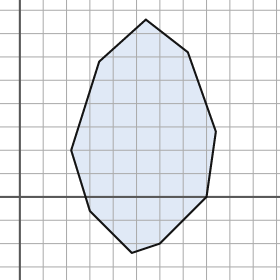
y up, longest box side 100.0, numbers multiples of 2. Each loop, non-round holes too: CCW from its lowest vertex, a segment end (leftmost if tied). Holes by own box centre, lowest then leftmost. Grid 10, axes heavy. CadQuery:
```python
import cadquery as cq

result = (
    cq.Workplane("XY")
    .moveTo(48.0, -24.0)
    .lineTo(60.0, -20.0)
    .lineTo(80.0, 0.0)
    .lineTo(84.0, 28.0)
    .lineTo(72.0, 62.0)
    .lineTo(54.0, 76.0)
    .lineTo(34.0, 58.0)
    .lineTo(22.0, 20.0)
    .lineTo(30.0, -6.0)
    .close()
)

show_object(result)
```